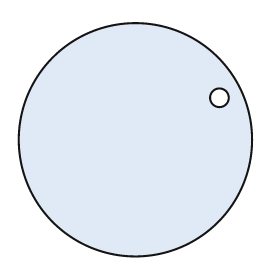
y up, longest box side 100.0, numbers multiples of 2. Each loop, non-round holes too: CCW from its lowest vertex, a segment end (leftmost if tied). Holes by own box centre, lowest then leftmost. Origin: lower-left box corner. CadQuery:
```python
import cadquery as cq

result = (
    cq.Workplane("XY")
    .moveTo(50.0, 50.0)
    .circle(50.0)
    .moveTo(86.0, 68.0)
    .circle(4.0)
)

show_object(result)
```